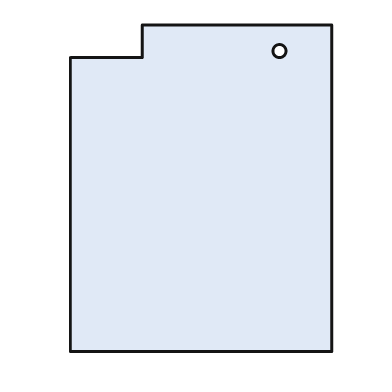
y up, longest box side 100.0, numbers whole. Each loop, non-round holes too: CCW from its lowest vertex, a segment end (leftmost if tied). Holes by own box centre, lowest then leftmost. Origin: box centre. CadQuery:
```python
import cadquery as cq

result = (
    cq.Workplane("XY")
    .moveTo(-40.0, -50.0)
    .lineTo(40.0, -50.0)
    .lineTo(40.0, 50.0)
    .lineTo(-18.0, 50.0)
    .lineTo(-18.0, 40.0)
    .lineTo(-40.0, 40.0)
    .close()
    .moveTo(24.0, 42.0)
    .circle(2.0)
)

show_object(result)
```